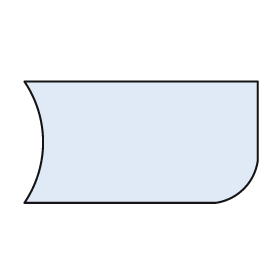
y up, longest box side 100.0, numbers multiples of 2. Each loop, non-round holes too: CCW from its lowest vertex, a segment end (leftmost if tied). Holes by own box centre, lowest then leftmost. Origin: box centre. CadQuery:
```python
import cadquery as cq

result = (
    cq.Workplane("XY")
    .moveTo(-50.0, -26.0)
    .lineTo(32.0, -26.0)
    .threePointArc((44.0, -20.0), (50.0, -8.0))
    .lineTo(50.0, 26.0)
    .lineTo(-50.0, 26.0)
    .threePointArc((-42.0, 0.0), (-50.0, -26.0))
    .close()
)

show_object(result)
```